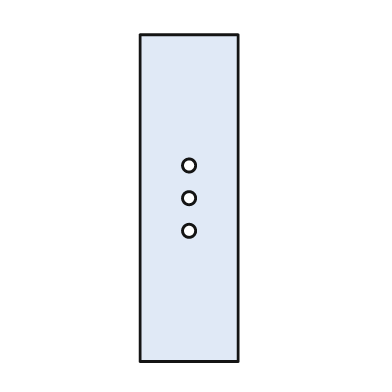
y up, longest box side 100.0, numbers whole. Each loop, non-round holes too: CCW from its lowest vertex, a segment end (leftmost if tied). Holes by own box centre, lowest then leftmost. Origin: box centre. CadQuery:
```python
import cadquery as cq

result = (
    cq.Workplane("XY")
    .moveTo(-15.0, -50.0)
    .lineTo(15.0, -50.0)
    .lineTo(15.0, 50.0)
    .lineTo(-15.0, 50.0)
    .close()
    .moveTo(0.0, -10.0)
    .circle(2.0)
    .moveTo(0.0, 0.0)
    .circle(2.0)
    .moveTo(0.0, 10.0)
    .circle(2.0)
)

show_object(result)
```